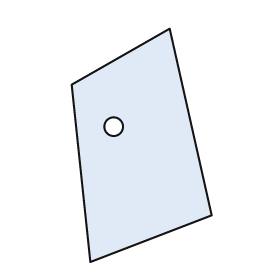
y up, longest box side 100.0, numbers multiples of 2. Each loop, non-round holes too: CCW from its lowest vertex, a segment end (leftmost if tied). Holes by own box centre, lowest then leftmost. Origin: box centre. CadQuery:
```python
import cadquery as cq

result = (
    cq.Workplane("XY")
    .moveTo(-22.0, -50.0)
    .lineTo(30.0, -30.0)
    .lineTo(12.0, 50.0)
    .lineTo(-30.0, 26.0)
    .close()
    .moveTo(-12.0, 8.0)
    .circle(4.0)
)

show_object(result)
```